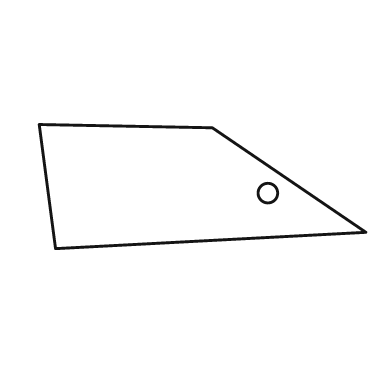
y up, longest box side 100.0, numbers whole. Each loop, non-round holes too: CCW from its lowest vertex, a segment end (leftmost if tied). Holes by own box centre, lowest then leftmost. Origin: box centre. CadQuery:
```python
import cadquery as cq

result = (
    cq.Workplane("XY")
    .moveTo(-45.0, -19.0)
    .lineTo(50.0, -14.0)
    .lineTo(3.0, 18.0)
    .lineTo(-50.0, 19.0)
    .close()
    .moveTo(20.0, -2.0)
    .circle(3.0)
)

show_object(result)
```